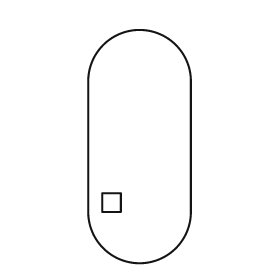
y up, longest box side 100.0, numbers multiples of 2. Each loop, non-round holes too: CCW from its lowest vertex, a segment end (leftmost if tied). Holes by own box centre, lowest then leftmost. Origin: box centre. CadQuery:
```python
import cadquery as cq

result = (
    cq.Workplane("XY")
    .moveTo(-22.0, -28.0)
    .threePointArc((0.0, -50.0), (22.0, -28.0))
    .lineTo(22.0, 28.0)
    .threePointArc((0.0, 50.0), (-22.0, 28.0))
    .close()
    .moveTo(-16.0, -28.0)
    .lineTo(-8.0, -28.0)
    .lineTo(-8.0, -20.0)
    .lineTo(-16.0, -20.0)
    .close()
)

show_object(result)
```